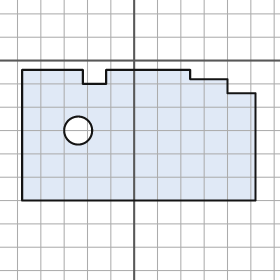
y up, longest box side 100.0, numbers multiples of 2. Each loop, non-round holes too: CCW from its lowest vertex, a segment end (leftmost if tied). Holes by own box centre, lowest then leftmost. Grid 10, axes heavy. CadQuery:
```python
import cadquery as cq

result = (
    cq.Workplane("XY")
    .moveTo(-48.0, -60.0)
    .lineTo(52.0, -60.0)
    .lineTo(52.0, -14.0)
    .lineTo(40.0, -14.0)
    .lineTo(40.0, -8.0)
    .lineTo(24.0, -8.0)
    .lineTo(24.0, -4.0)
    .lineTo(-12.0, -4.0)
    .lineTo(-12.0, -10.0)
    .lineTo(-22.0, -10.0)
    .lineTo(-22.0, -4.0)
    .lineTo(-48.0, -4.0)
    .close()
    .moveTo(-24.0, -30.0)
    .circle(6.0)
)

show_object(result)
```